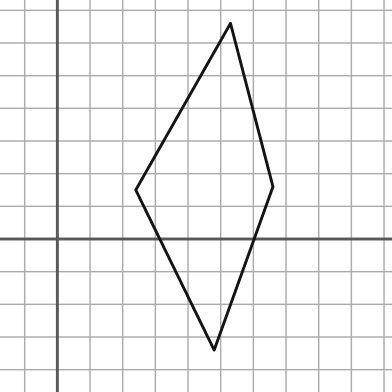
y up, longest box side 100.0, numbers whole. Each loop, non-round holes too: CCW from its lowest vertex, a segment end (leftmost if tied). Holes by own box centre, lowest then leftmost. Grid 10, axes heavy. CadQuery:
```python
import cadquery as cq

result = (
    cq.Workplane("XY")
    .moveTo(48.0, -34.0)
    .lineTo(66.0, 16.0)
    .lineTo(53.0, 66.0)
    .lineTo(24.0, 15.0)
    .close()
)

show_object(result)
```